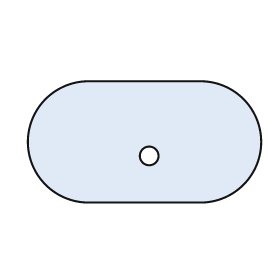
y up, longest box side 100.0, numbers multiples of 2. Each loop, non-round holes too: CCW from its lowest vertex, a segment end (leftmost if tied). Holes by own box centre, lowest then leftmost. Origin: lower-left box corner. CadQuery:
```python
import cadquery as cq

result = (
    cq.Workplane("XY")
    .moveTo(26.0, 0.0)
    .lineTo(74.0, 0.0)
    .threePointArc((100.0, 26.0), (74.0, 52.0))
    .lineTo(26.0, 52.0)
    .threePointArc((0.0, 26.0), (26.0, 0.0))
    .close()
    .moveTo(52.0, 20.0)
    .circle(4.0)
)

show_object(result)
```